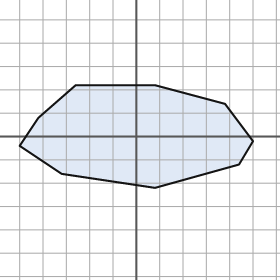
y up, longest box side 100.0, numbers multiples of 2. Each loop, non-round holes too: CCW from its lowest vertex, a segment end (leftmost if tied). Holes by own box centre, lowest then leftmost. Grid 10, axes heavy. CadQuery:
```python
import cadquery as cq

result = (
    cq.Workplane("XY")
    .moveTo(8.0, -22.0)
    .lineTo(44.0, -12.0)
    .lineTo(50.0, -2.0)
    .lineTo(38.0, 14.0)
    .lineTo(8.0, 22.0)
    .lineTo(-26.0, 22.0)
    .lineTo(-42.0, 8.0)
    .lineTo(-50.0, -4.0)
    .lineTo(-32.0, -16.0)
    .close()
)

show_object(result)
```